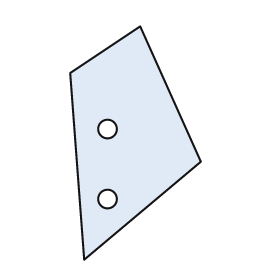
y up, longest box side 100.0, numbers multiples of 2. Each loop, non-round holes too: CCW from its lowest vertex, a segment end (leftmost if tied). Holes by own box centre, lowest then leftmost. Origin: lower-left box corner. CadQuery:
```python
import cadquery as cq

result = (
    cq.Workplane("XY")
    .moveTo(6.0, 0.0)
    .lineTo(56.0, 42.0)
    .lineTo(30.0, 100.0)
    .lineTo(0.0, 80.0)
    .close()
    .moveTo(16.0, 26.0)
    .circle(4.0)
    .moveTo(16.0, 56.0)
    .circle(4.0)
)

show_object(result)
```